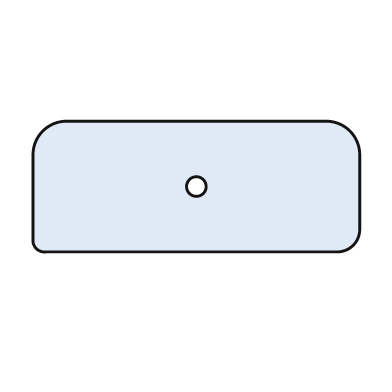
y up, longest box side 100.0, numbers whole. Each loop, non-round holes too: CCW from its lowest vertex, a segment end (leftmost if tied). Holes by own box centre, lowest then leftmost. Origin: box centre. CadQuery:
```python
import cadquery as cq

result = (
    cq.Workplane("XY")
    .moveTo(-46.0, -20.0)
    .lineTo(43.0, -20.0)
    .threePointArc((48.0, -18.0), (50.0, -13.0))
    .lineTo(50.0, 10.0)
    .threePointArc((47.0, 17.0), (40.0, 20.0))
    .lineTo(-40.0, 20.0)
    .threePointArc((-47.0, 17.0), (-50.0, 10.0))
    .lineTo(-50.0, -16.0)
    .threePointArc((-49.0, -19.0), (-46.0, -20.0))
    .close()
    .moveTo(0.0, 0.0)
    .circle(3.0)
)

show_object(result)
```